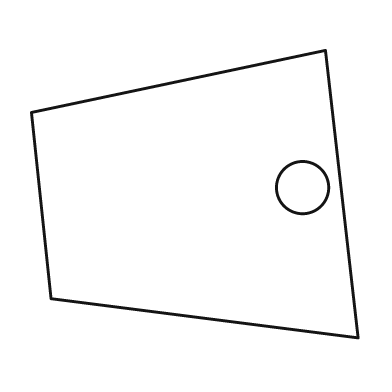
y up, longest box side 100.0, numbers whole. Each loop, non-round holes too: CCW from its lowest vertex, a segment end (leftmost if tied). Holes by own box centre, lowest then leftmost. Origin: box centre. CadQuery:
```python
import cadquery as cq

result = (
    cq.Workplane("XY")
    .moveTo(50.0, -44.0)
    .lineTo(40.0, 44.0)
    .lineTo(-50.0, 25.0)
    .lineTo(-44.0, -32.0)
    .close()
    .moveTo(33.0, 2.0)
    .circle(8.0)
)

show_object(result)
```